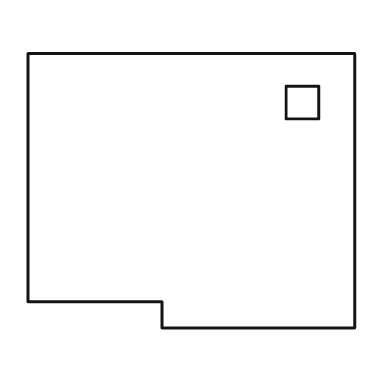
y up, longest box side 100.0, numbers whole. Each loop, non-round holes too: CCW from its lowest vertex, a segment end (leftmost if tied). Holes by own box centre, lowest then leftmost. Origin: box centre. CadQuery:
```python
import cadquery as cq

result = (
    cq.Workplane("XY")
    .moveTo(-9.0, -42.0)
    .lineTo(50.0, -42.0)
    .lineTo(50.0, 42.0)
    .lineTo(-50.0, 42.0)
    .lineTo(-50.0, -34.0)
    .lineTo(-9.0, -34.0)
    .close()
    .moveTo(29.0, 22.0)
    .lineTo(39.0, 22.0)
    .lineTo(39.0, 32.0)
    .lineTo(29.0, 32.0)
    .close()
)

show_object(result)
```